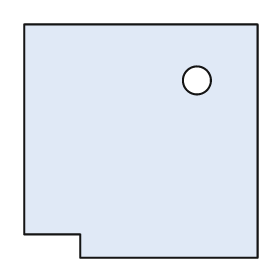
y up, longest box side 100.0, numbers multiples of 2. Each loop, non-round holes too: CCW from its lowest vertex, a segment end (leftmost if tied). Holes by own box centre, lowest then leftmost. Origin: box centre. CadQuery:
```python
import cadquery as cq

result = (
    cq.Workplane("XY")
    .moveTo(-26.0, -50.0)
    .lineTo(50.0, -50.0)
    .lineTo(50.0, 50.0)
    .lineTo(-50.0, 50.0)
    .lineTo(-50.0, -40.0)
    .lineTo(-26.0, -40.0)
    .close()
    .moveTo(24.0, 26.0)
    .circle(6.0)
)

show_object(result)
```